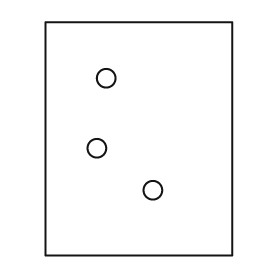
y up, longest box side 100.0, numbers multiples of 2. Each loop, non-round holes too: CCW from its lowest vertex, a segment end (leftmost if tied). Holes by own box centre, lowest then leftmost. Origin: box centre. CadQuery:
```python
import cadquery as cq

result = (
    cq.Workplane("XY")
    .moveTo(-40.0, -50.0)
    .lineTo(40.0, -50.0)
    .lineTo(40.0, 50.0)
    .lineTo(-40.0, 50.0)
    .close()
    .moveTo(6.0, -22.0)
    .circle(4.0)
    .moveTo(-18.0, -4.0)
    .circle(4.0)
    .moveTo(-14.0, 26.0)
    .circle(4.0)
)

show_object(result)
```